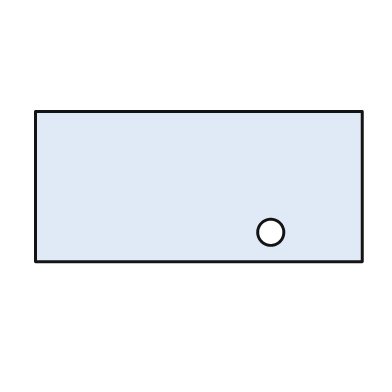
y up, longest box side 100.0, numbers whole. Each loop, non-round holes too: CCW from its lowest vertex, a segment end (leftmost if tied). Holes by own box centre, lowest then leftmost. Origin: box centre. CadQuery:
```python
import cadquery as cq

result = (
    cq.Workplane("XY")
    .moveTo(-50.0, -23.0)
    .lineTo(50.0, -23.0)
    .lineTo(50.0, 23.0)
    .lineTo(-50.0, 23.0)
    .close()
    .moveTo(22.0, -14.0)
    .circle(4.0)
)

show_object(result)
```